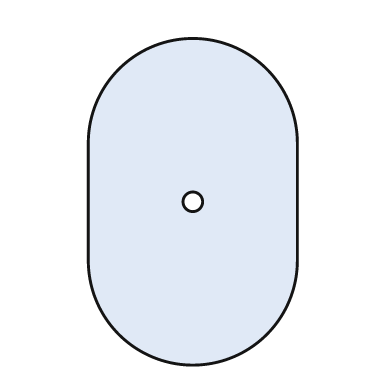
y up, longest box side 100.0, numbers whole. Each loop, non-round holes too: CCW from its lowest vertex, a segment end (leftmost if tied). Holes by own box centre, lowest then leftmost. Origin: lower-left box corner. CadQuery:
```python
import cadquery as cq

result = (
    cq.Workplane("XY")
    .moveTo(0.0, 32.0)
    .threePointArc((32.0, 0.0), (64.0, 32.0))
    .lineTo(64.0, 68.0)
    .threePointArc((32.0, 100.0), (0.0, 68.0))
    .close()
    .moveTo(32.0, 50.0)
    .circle(3.0)
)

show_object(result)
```